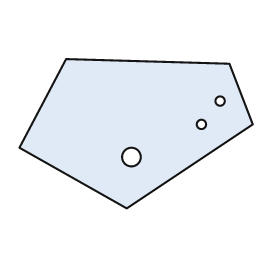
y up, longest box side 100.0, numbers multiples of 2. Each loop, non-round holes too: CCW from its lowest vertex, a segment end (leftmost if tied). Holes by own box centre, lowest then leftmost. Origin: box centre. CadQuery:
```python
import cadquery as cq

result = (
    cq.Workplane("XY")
    .moveTo(-4.0, -32.0)
    .lineTo(50.0, 4.0)
    .lineTo(40.0, 30.0)
    .lineTo(-30.0, 32.0)
    .lineTo(-50.0, -6.0)
    .close()
    .moveTo(-2.0, -10.0)
    .circle(4.0)
    .moveTo(28.0, 4.0)
    .circle(2.0)
    .moveTo(36.0, 14.0)
    .circle(2.0)
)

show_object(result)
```